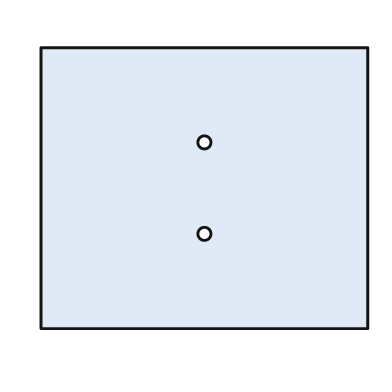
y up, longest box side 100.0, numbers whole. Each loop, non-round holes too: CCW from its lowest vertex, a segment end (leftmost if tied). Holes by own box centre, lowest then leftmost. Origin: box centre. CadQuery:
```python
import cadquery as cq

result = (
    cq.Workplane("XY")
    .moveTo(-50.0, -43.0)
    .lineTo(50.0, -43.0)
    .lineTo(50.0, 43.0)
    .lineTo(-50.0, 43.0)
    .close()
    .moveTo(0.0, -14.0)
    .circle(2.0)
    .moveTo(0.0, 14.0)
    .circle(2.0)
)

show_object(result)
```